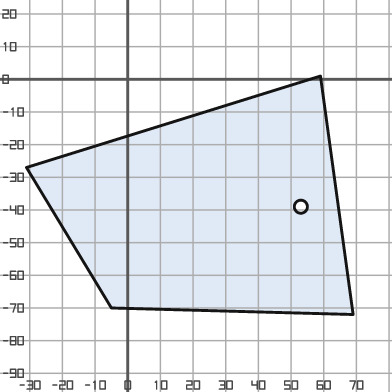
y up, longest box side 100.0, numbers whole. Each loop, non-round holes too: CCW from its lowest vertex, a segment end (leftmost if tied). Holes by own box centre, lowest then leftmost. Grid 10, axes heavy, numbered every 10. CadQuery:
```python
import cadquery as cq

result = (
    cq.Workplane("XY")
    .moveTo(69.0, -72.0)
    .lineTo(59.0, 1.0)
    .lineTo(-31.0, -27.0)
    .lineTo(-5.0, -70.0)
    .close()
    .moveTo(53.0, -39.0)
    .circle(2.0)
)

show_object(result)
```